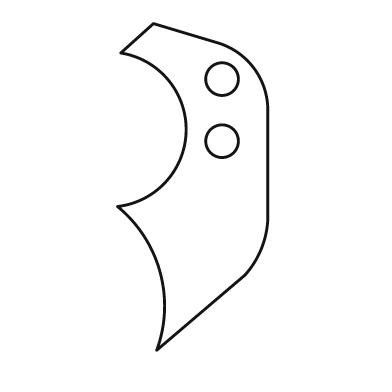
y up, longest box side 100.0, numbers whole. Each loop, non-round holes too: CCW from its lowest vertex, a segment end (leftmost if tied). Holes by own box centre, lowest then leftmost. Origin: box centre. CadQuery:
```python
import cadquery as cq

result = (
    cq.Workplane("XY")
    .moveTo(-11.0, -50.0)
    .lineTo(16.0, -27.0)
    .threePointArc((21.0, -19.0), (23.0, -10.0))
    .lineTo(23.0, 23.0)
    .threePointArc((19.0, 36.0), (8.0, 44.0))
    .lineTo(-12.0, 50.0)
    .lineTo(-22.0, 41.0)
    .threePointArc((-2.0, 17.0), (-23.0, -6.0))
    .threePointArc((-10.0, -26.0), (-11.0, -50.0))
    .close()
    .moveTo(9.0, 14.0)
    .circle(5.0)
    .moveTo(9.0, 33.0)
    .circle(5.0)
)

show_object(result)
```